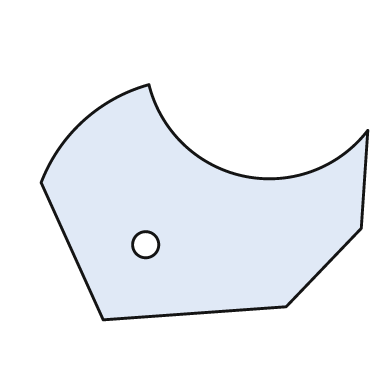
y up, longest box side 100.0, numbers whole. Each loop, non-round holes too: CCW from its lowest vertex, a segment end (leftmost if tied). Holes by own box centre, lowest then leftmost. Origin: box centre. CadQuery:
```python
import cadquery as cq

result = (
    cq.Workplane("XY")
    .moveTo(-31.0, -36.0)
    .lineTo(25.0, -32.0)
    .lineTo(48.0, -8.0)
    .lineTo(50.0, 22.0)
    .threePointArc((12.0, 8.0), (-17.0, 36.0))
    .threePointArc((-37.0, 25.0), (-50.0, 6.0))
    .close()
    .moveTo(-18.0, -13.0)
    .circle(4.0)
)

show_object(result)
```